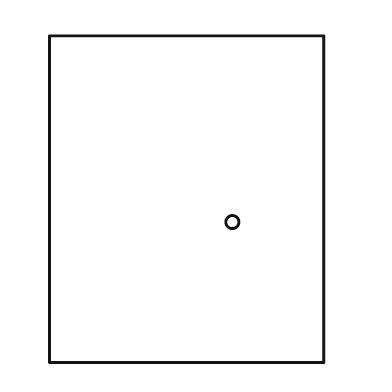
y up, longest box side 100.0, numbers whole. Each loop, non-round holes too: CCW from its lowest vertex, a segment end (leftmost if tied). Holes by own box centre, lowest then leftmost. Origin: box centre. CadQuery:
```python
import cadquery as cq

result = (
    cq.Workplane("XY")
    .moveTo(-42.0, -50.0)
    .lineTo(42.0, -50.0)
    .lineTo(42.0, 50.0)
    .lineTo(-42.0, 50.0)
    .close()
    .moveTo(14.0, -7.0)
    .circle(2.0)
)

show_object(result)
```